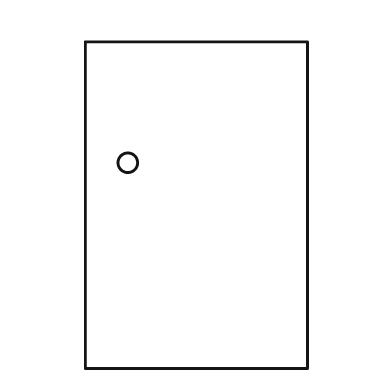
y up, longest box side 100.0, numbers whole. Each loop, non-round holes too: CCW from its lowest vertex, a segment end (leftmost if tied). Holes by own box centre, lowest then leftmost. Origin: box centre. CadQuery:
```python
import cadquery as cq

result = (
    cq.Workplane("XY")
    .moveTo(-34.0, -50.0)
    .lineTo(34.0, -50.0)
    .lineTo(34.0, 50.0)
    .lineTo(-34.0, 50.0)
    .close()
    .moveTo(-21.0, 13.0)
    .circle(3.0)
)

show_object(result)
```